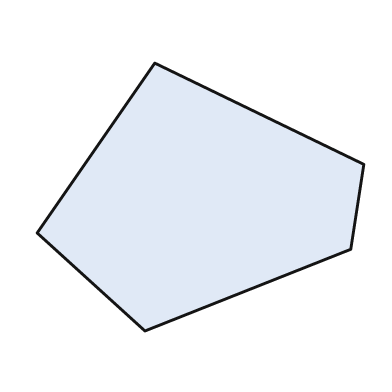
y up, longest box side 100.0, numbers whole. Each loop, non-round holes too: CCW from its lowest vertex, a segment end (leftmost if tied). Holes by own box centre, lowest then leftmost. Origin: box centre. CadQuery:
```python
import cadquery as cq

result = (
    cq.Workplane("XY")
    .moveTo(-17.0, -41.0)
    .lineTo(46.0, -16.0)
    .lineTo(50.0, 10.0)
    .lineTo(-14.0, 41.0)
    .lineTo(-50.0, -11.0)
    .close()
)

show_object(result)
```